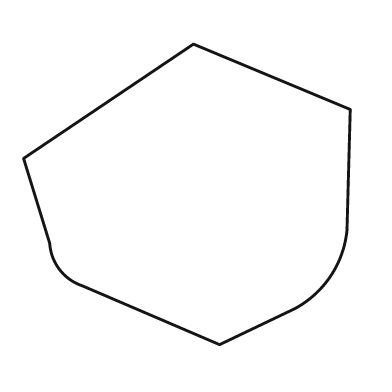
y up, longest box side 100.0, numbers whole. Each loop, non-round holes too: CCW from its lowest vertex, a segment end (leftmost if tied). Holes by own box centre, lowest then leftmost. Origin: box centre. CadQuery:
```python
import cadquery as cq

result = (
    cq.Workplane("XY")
    .moveTo(10.0, -46.0)
    .lineTo(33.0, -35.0)
    .threePointArc((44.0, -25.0), (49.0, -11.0))
    .lineTo(50.0, 26.0)
    .lineTo(2.0, 46.0)
    .lineTo(-50.0, 11.0)
    .lineTo(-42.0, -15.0)
    .threePointArc((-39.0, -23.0), (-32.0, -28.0))
    .close()
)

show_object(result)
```